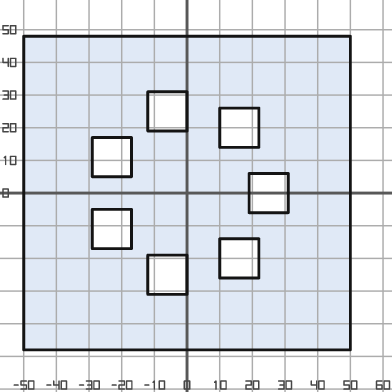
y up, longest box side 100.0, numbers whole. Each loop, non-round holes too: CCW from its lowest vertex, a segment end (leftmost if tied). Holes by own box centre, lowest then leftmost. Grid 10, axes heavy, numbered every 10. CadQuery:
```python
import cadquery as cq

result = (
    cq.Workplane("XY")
    .moveTo(-50.0, -48.0)
    .lineTo(50.0, -48.0)
    .lineTo(50.0, 48.0)
    .lineTo(-50.0, 48.0)
    .close()
    .moveTo(-12.0, -31.0)
    .lineTo(0.0, -31.0)
    .lineTo(0.0, -19.0)
    .lineTo(-12.0, -19.0)
    .close()
    .moveTo(10.0, -26.0)
    .lineTo(22.0, -26.0)
    .lineTo(22.0, -14.0)
    .lineTo(10.0, -14.0)
    .close()
    .moveTo(-29.0, -17.0)
    .lineTo(-17.0, -17.0)
    .lineTo(-17.0, -5.0)
    .lineTo(-29.0, -5.0)
    .close()
    .moveTo(19.0, -6.0)
    .lineTo(31.0, -6.0)
    .lineTo(31.0, 6.0)
    .lineTo(19.0, 6.0)
    .close()
    .moveTo(-29.0, 5.0)
    .lineTo(-17.0, 5.0)
    .lineTo(-17.0, 17.0)
    .lineTo(-29.0, 17.0)
    .close()
    .moveTo(10.0, 14.0)
    .lineTo(22.0, 14.0)
    .lineTo(22.0, 26.0)
    .lineTo(10.0, 26.0)
    .close()
    .moveTo(-12.0, 19.0)
    .lineTo(0.0, 19.0)
    .lineTo(0.0, 31.0)
    .lineTo(-12.0, 31.0)
    .close()
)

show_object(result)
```